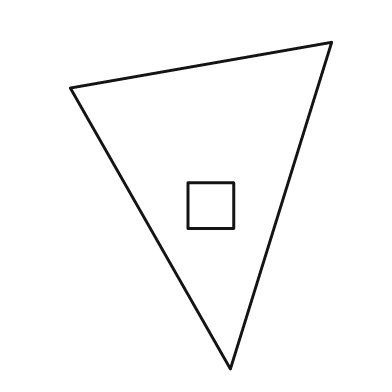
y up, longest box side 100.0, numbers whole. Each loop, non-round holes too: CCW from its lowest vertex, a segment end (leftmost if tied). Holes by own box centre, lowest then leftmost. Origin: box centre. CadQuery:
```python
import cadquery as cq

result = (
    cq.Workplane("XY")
    .moveTo(9.0, -50.0)
    .lineTo(40.0, 50.0)
    .lineTo(-40.0, 36.0)
    .close()
    .moveTo(-4.0, -7.0)
    .lineTo(10.0, -7.0)
    .lineTo(10.0, 7.0)
    .lineTo(-4.0, 7.0)
    .close()
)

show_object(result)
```